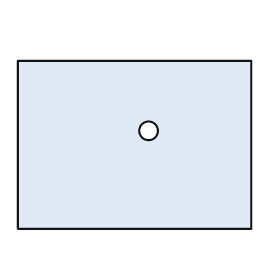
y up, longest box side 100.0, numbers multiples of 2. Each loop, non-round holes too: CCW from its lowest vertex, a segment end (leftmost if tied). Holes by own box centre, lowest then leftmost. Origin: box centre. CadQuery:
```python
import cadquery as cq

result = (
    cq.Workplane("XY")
    .moveTo(-50.0, -36.0)
    .lineTo(50.0, -36.0)
    .lineTo(50.0, 36.0)
    .lineTo(-50.0, 36.0)
    .close()
    .moveTo(6.0, 6.0)
    .circle(4.0)
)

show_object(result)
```